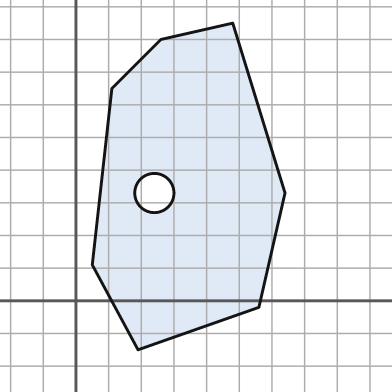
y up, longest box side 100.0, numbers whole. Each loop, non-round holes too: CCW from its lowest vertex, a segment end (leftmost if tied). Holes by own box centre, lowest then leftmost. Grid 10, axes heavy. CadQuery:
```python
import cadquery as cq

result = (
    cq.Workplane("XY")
    .moveTo(19.0, -15.0)
    .lineTo(56.0, -2.0)
    .lineTo(64.0, 33.0)
    .lineTo(48.0, 85.0)
    .lineTo(26.0, 80.0)
    .lineTo(11.0, 65.0)
    .lineTo(5.0, 11.0)
    .close()
    .moveTo(24.0, 33.0)
    .circle(6.0)
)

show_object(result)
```